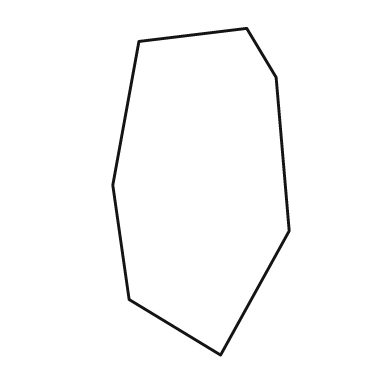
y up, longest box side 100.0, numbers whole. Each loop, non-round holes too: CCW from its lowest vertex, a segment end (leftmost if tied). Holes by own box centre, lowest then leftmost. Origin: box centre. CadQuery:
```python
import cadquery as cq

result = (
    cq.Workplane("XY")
    .moveTo(6.0, -50.0)
    .lineTo(27.0, -12.0)
    .lineTo(23.0, 35.0)
    .lineTo(14.0, 50.0)
    .lineTo(-19.0, 46.0)
    .lineTo(-27.0, 2.0)
    .lineTo(-22.0, -33.0)
    .close()
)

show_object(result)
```